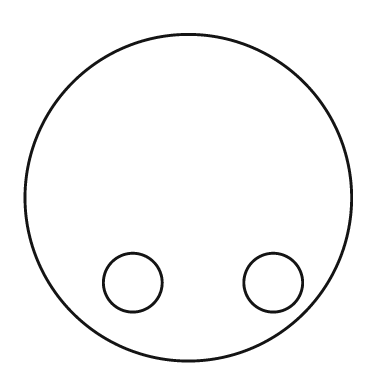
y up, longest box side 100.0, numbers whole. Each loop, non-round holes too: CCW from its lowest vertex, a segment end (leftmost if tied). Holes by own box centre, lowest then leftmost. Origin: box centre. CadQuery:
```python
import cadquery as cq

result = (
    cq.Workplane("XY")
    .moveTo(0.0, 0.0)
    .circle(50.0)
    .moveTo(-17.0, -26.0)
    .circle(9.0)
    .moveTo(26.0, -26.0)
    .circle(9.0)
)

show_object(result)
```